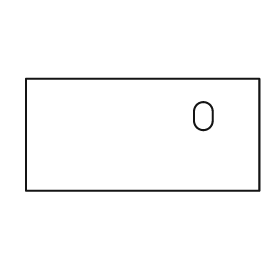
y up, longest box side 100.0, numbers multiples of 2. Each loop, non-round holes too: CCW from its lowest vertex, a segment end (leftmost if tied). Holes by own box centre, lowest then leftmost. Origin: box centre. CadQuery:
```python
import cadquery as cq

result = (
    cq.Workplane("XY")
    .moveTo(-50.0, -24.0)
    .lineTo(50.0, -24.0)
    .lineTo(50.0, 24.0)
    .lineTo(-50.0, 24.0)
    .close()
    .moveTo(22.0, 6.0)
    .threePointArc((26.0, 2.0), (30.0, 6.0))
    .lineTo(30.0, 10.0)
    .threePointArc((26.0, 14.0), (22.0, 10.0))
    .close()
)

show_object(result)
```